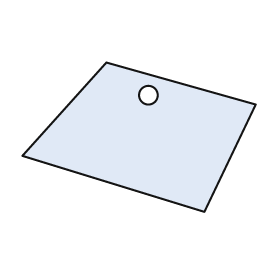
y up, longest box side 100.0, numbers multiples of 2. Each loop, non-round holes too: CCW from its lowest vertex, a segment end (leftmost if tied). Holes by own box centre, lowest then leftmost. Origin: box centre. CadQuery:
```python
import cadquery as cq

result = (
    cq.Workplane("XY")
    .moveTo(28.0, -32.0)
    .lineTo(50.0, 14.0)
    .lineTo(-14.0, 32.0)
    .lineTo(-50.0, -8.0)
    .close()
    .moveTo(4.0, 18.0)
    .circle(4.0)
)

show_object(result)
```